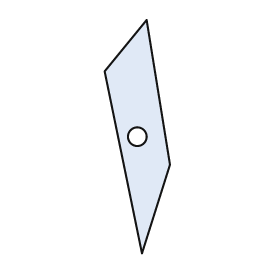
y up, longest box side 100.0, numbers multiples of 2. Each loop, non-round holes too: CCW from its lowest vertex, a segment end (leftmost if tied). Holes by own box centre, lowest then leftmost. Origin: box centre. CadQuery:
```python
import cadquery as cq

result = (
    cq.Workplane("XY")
    .moveTo(2.0, -50.0)
    .lineTo(14.0, -12.0)
    .lineTo(4.0, 50.0)
    .lineTo(-14.0, 28.0)
    .close()
    .moveTo(0.0, 0.0)
    .circle(4.0)
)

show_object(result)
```